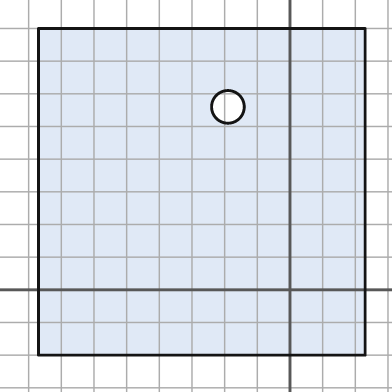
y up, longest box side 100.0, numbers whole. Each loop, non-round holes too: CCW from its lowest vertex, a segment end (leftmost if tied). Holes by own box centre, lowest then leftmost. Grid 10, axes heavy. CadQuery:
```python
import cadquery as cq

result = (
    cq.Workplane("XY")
    .moveTo(-77.0, -20.0)
    .lineTo(23.0, -20.0)
    .lineTo(23.0, 80.0)
    .lineTo(-77.0, 80.0)
    .close()
    .moveTo(-19.0, 56.0)
    .circle(5.0)
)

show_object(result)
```